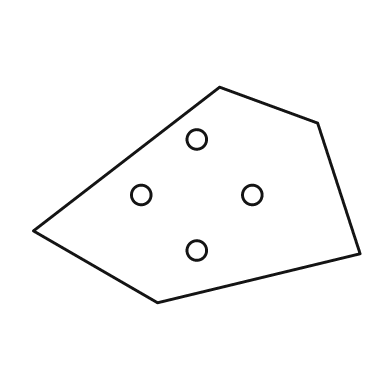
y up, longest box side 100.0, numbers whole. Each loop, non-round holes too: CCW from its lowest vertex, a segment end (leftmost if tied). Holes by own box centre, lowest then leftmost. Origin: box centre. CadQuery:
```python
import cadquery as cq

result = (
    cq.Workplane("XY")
    .moveTo(-12.0, -33.0)
    .lineTo(50.0, -18.0)
    .lineTo(37.0, 22.0)
    .lineTo(7.0, 33.0)
    .lineTo(-50.0, -11.0)
    .close()
    .moveTo(0.0, -17.0)
    .circle(3.0)
    .moveTo(-17.0, 0.0)
    .circle(3.0)
    .moveTo(17.0, 0.0)
    .circle(3.0)
    .moveTo(0.0, 17.0)
    .circle(3.0)
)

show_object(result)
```